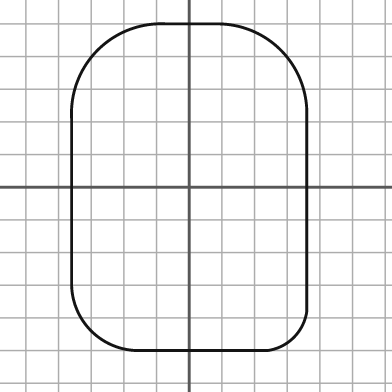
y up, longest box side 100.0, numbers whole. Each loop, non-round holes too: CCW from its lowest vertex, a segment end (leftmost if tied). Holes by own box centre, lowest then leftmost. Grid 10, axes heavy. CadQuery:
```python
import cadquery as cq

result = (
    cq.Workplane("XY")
    .moveTo(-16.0, -50.0)
    .lineTo(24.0, -50.0)
    .threePointArc((32.0, -46.0), (36.0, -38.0))
    .lineTo(36.0, 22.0)
    .threePointArc((28.0, 42.0), (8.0, 50.0))
    .lineTo(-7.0, 50.0)
    .threePointArc((-28.0, 42.0), (-36.0, 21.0))
    .lineTo(-36.0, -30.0)
    .threePointArc((-30.0, -44.0), (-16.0, -50.0))
    .close()
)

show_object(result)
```